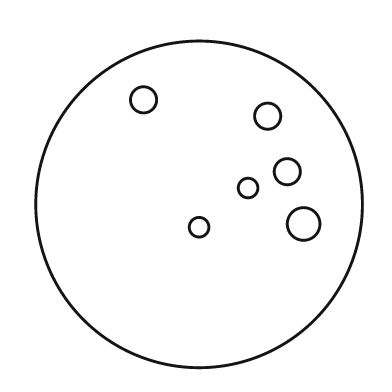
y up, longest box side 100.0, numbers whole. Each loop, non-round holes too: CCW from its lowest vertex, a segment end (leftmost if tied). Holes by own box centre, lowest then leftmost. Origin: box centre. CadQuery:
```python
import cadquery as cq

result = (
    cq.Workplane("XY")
    .moveTo(0.0, 0.0)
    .circle(50.0)
    .moveTo(0.0, -7.0)
    .circle(3.0)
    .moveTo(32.0, -6.0)
    .circle(5.0)
    .moveTo(15.0, 5.0)
    .circle(3.0)
    .moveTo(27.0, 10.0)
    .circle(4.0)
    .moveTo(21.0, 27.0)
    .circle(4.0)
    .moveTo(-17.0, 32.0)
    .circle(4.0)
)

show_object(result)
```